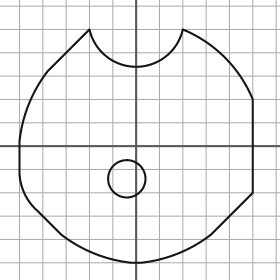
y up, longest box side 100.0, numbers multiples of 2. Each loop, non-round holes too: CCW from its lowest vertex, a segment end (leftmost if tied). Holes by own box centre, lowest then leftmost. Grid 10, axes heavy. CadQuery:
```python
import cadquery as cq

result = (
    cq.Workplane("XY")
    .moveTo(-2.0, -50.0)
    .lineTo(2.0, -50.0)
    .threePointArc((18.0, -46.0), (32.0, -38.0))
    .lineTo(50.0, -20.0)
    .lineTo(50.0, 20.0)
    .threePointArc((38.0, 38.0), (20.0, 50.0))
    .threePointArc((0.0, 34.0), (-20.0, 50.0))
    .lineTo(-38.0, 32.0)
    .threePointArc((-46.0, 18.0), (-50.0, 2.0))
    .lineTo(-50.0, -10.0)
    .threePointArc((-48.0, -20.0), (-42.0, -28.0))
    .lineTo(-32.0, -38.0)
    .threePointArc((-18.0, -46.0), (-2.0, -50.0))
    .close()
    .moveTo(-4.0, -14.0)
    .circle(8.0)
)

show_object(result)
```